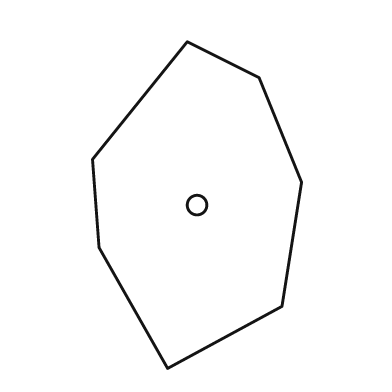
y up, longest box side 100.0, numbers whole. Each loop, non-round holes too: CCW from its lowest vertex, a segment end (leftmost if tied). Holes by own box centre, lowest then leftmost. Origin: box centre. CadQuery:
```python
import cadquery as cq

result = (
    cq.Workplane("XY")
    .moveTo(-9.0, -50.0)
    .lineTo(26.0, -31.0)
    .lineTo(32.0, 7.0)
    .lineTo(19.0, 39.0)
    .lineTo(-3.0, 50.0)
    .lineTo(-32.0, 14.0)
    .lineTo(-30.0, -13.0)
    .close()
    .moveTo(0.0, 0.0)
    .circle(3.0)
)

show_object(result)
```